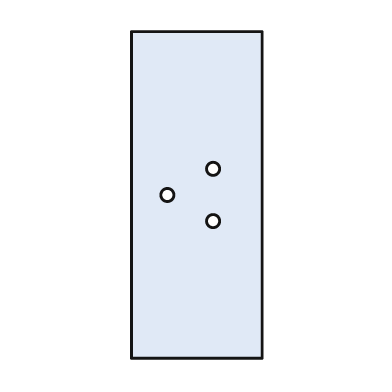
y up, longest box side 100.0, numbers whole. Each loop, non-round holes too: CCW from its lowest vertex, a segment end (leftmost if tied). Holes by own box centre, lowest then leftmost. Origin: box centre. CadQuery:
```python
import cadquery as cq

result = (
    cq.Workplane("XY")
    .moveTo(-20.0, -50.0)
    .lineTo(20.0, -50.0)
    .lineTo(20.0, 50.0)
    .lineTo(-20.0, 50.0)
    .close()
    .moveTo(5.0, -8.0)
    .circle(2.0)
    .moveTo(-9.0, 0.0)
    .circle(2.0)
    .moveTo(5.0, 8.0)
    .circle(2.0)
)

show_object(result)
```